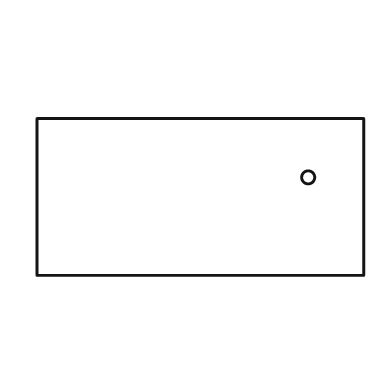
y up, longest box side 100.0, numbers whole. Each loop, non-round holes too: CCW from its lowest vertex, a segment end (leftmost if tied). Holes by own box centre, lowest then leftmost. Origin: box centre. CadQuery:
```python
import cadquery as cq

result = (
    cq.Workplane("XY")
    .moveTo(-50.0, -24.0)
    .lineTo(50.0, -24.0)
    .lineTo(50.0, 24.0)
    .lineTo(-50.0, 24.0)
    .close()
    .moveTo(33.0, 6.0)
    .circle(2.0)
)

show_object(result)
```